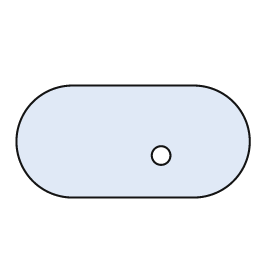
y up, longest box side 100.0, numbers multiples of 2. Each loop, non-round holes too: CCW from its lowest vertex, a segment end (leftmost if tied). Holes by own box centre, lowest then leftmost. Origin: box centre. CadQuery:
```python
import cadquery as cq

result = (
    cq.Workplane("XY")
    .moveTo(-26.0, -24.0)
    .lineTo(26.0, -24.0)
    .threePointArc((50.0, 0.0), (26.0, 24.0))
    .lineTo(-26.0, 24.0)
    .threePointArc((-50.0, 0.0), (-26.0, -24.0))
    .close()
    .moveTo(12.0, -6.0)
    .circle(4.0)
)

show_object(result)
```